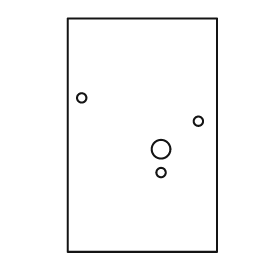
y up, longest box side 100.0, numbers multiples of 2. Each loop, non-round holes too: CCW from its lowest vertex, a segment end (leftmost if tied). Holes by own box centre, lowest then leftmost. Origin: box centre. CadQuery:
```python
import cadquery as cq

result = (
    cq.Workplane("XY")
    .moveTo(-32.0, -50.0)
    .lineTo(32.0, -50.0)
    .lineTo(32.0, 50.0)
    .lineTo(-32.0, 50.0)
    .close()
    .moveTo(8.0, -16.0)
    .circle(2.0)
    .moveTo(8.0, -6.0)
    .circle(4.0)
    .moveTo(24.0, 6.0)
    .circle(2.0)
    .moveTo(-26.0, 16.0)
    .circle(2.0)
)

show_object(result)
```